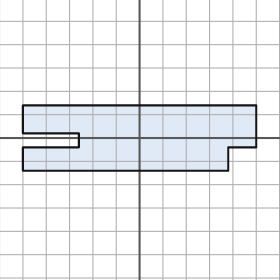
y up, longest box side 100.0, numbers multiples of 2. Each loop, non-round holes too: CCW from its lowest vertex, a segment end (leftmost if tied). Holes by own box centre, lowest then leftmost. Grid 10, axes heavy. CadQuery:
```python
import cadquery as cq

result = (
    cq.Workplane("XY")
    .moveTo(-50.0, -14.0)
    .lineTo(38.0, -14.0)
    .lineTo(38.0, -4.0)
    .lineTo(50.0, -4.0)
    .lineTo(50.0, 14.0)
    .lineTo(-50.0, 14.0)
    .lineTo(-50.0, 2.0)
    .lineTo(-26.0, 2.0)
    .lineTo(-26.0, -4.0)
    .lineTo(-50.0, -4.0)
    .close()
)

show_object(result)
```